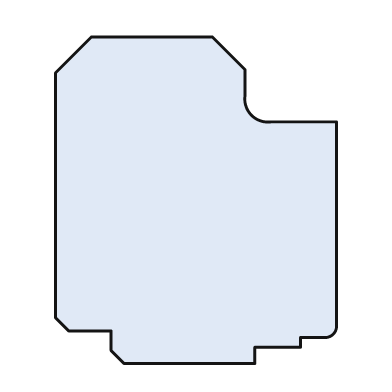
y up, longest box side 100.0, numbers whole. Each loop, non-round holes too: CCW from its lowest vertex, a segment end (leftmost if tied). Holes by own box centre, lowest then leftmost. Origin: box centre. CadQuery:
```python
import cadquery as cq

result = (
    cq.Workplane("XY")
    .moveTo(-22.0, -50.0)
    .lineTo(18.0, -50.0)
    .lineTo(18.0, -45.0)
    .lineTo(32.0, -45.0)
    .lineTo(32.0, -42.0)
    .lineTo(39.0, -42.0)
    .threePointArc((42.0, -41.0), (43.0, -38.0))
    .lineTo(43.0, 24.0)
    .lineTo(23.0, 24.0)
    .threePointArc((17.0, 26.0), (15.0, 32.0))
    .lineTo(15.0, 40.0)
    .lineTo(5.0, 50.0)
    .lineTo(-32.0, 50.0)
    .lineTo(-43.0, 39.0)
    .lineTo(-43.0, -36.0)
    .lineTo(-39.0, -40.0)
    .lineTo(-26.0, -40.0)
    .lineTo(-26.0, -46.0)
    .close()
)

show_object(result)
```